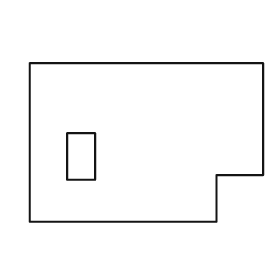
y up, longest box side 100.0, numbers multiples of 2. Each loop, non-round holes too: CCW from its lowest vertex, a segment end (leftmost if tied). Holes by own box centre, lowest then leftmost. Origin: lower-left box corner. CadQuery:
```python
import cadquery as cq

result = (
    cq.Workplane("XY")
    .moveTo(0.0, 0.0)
    .lineTo(80.0, 0.0)
    .lineTo(80.0, 20.0)
    .lineTo(100.0, 20.0)
    .lineTo(100.0, 68.0)
    .lineTo(0.0, 68.0)
    .close()
    .moveTo(16.0, 18.0)
    .lineTo(28.0, 18.0)
    .lineTo(28.0, 38.0)
    .lineTo(16.0, 38.0)
    .close()
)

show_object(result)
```